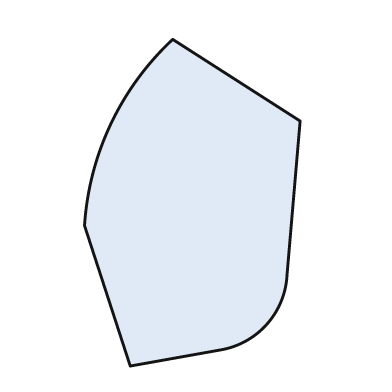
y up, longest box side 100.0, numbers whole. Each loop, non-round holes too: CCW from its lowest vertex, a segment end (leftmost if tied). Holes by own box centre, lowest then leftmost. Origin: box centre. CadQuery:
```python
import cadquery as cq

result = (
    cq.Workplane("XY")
    .moveTo(-19.0, -50.0)
    .lineTo(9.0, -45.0)
    .threePointArc((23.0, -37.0), (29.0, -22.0))
    .lineTo(33.0, 25.0)
    .lineTo(-6.0, 50.0)
    .threePointArc((-25.0, 24.0), (-33.0, -7.0))
    .close()
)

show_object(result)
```